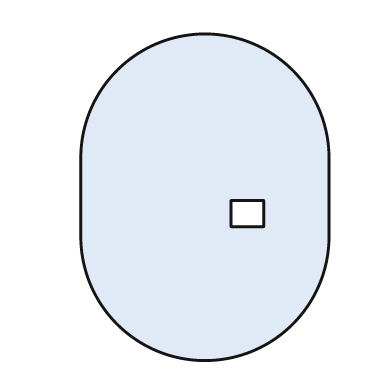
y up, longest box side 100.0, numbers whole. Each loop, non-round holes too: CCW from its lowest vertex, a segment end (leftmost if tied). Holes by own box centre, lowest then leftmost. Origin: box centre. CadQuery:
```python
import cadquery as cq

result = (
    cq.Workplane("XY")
    .moveTo(-38.0, -12.0)
    .threePointArc((0.0, -50.0), (38.0, -12.0))
    .lineTo(38.0, 12.0)
    .threePointArc((0.0, 50.0), (-38.0, 12.0))
    .close()
    .moveTo(8.0, -9.0)
    .lineTo(18.0, -9.0)
    .lineTo(18.0, -1.0)
    .lineTo(8.0, -1.0)
    .close()
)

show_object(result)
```